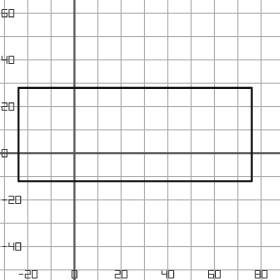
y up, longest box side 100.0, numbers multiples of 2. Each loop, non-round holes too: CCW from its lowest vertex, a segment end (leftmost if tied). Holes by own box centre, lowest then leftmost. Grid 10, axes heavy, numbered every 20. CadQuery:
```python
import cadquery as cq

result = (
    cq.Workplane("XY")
    .moveTo(-24.0, -12.0)
    .lineTo(76.0, -12.0)
    .lineTo(76.0, 28.0)
    .lineTo(-24.0, 28.0)
    .close()
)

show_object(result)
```